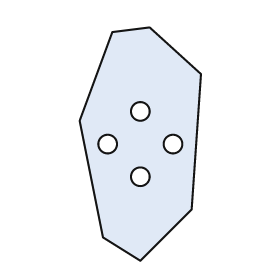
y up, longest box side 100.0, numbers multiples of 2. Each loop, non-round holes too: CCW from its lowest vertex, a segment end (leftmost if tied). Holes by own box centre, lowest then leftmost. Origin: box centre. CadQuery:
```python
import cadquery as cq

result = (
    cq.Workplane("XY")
    .moveTo(0.0, -50.0)
    .lineTo(22.0, -28.0)
    .lineTo(26.0, 30.0)
    .lineTo(4.0, 50.0)
    .lineTo(-12.0, 48.0)
    .lineTo(-26.0, 10.0)
    .lineTo(-16.0, -40.0)
    .close()
    .moveTo(0.0, -14.0)
    .circle(4.0)
    .moveTo(-14.0, 0.0)
    .circle(4.0)
    .moveTo(14.0, 0.0)
    .circle(4.0)
    .moveTo(0.0, 14.0)
    .circle(4.0)
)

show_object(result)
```